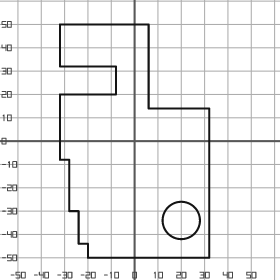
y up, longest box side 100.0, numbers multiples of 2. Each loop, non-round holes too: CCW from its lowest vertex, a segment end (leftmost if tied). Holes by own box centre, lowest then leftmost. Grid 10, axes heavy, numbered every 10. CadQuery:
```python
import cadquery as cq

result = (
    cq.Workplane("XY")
    .moveTo(-20.0, -50.0)
    .lineTo(32.0, -50.0)
    .lineTo(32.0, 14.0)
    .lineTo(6.0, 14.0)
    .lineTo(6.0, 50.0)
    .lineTo(-32.0, 50.0)
    .lineTo(-32.0, 32.0)
    .lineTo(-8.0, 32.0)
    .lineTo(-8.0, 20.0)
    .lineTo(-32.0, 20.0)
    .lineTo(-32.0, -8.0)
    .lineTo(-28.0, -8.0)
    .lineTo(-28.0, -30.0)
    .lineTo(-24.0, -30.0)
    .lineTo(-24.0, -44.0)
    .lineTo(-20.0, -44.0)
    .close()
    .moveTo(20.0, -34.0)
    .circle(8.0)
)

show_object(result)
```